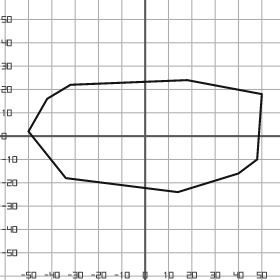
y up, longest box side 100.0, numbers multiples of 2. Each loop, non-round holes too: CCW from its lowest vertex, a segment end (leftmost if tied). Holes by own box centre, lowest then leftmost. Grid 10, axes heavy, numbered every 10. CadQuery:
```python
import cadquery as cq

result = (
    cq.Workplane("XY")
    .moveTo(14.0, -24.0)
    .lineTo(40.0, -16.0)
    .lineTo(48.0, -10.0)
    .lineTo(50.0, 18.0)
    .lineTo(18.0, 24.0)
    .lineTo(-32.0, 22.0)
    .lineTo(-42.0, 16.0)
    .lineTo(-50.0, 2.0)
    .lineTo(-34.0, -18.0)
    .close()
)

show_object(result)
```